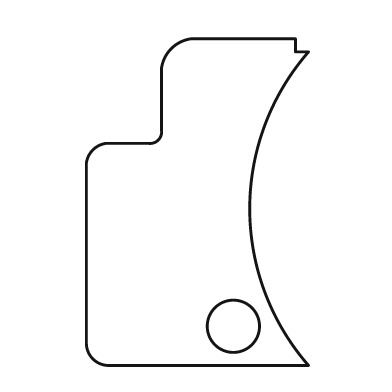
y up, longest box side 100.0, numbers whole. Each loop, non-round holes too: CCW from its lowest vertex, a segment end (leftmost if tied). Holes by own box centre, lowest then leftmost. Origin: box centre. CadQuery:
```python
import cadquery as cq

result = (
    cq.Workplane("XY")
    .moveTo(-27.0, -50.0)
    .lineTo(34.0, -50.0)
    .threePointArc((16.0, -2.0), (34.0, 46.0))
    .lineTo(30.0, 46.0)
    .lineTo(30.0, 50.0)
    .lineTo(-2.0, 50.0)
    .threePointArc((-8.0, 47.0), (-11.0, 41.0))
    .lineTo(-11.0, 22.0)
    .threePointArc((-12.0, 19.0), (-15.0, 18.0))
    .lineTo(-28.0, 18.0)
    .threePointArc((-32.0, 16.0), (-34.0, 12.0))
    .lineTo(-34.0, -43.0)
    .threePointArc((-32.0, -48.0), (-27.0, -50.0))
    .close()
    .moveTo(11.0, -38.0)
    .circle(8.0)
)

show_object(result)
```